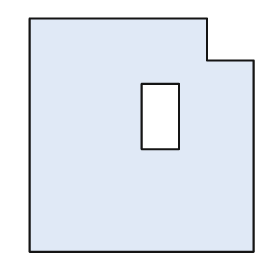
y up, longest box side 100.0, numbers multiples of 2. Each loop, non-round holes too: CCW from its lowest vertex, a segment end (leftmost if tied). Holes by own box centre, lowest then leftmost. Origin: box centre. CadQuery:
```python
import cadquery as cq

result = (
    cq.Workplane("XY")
    .moveTo(-48.0, -50.0)
    .lineTo(48.0, -50.0)
    .lineTo(48.0, 32.0)
    .lineTo(28.0, 32.0)
    .lineTo(28.0, 50.0)
    .lineTo(-48.0, 50.0)
    .close()
    .moveTo(0.0, -6.0)
    .lineTo(16.0, -6.0)
    .lineTo(16.0, 22.0)
    .lineTo(0.0, 22.0)
    .close()
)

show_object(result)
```